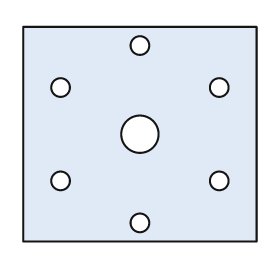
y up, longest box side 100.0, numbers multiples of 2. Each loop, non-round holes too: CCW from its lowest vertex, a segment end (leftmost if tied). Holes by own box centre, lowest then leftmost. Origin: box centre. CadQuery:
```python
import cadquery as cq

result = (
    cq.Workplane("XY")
    .moveTo(-50.0, -46.0)
    .lineTo(50.0, -46.0)
    .lineTo(50.0, 46.0)
    .lineTo(-50.0, 46.0)
    .close()
    .moveTo(0.0, -38.0)
    .circle(4.0)
    .moveTo(-34.0, -20.0)
    .circle(4.0)
    .moveTo(34.0, -20.0)
    .circle(4.0)
    .moveTo(0.0, 0.0)
    .circle(8.0)
    .moveTo(-34.0, 20.0)
    .circle(4.0)
    .moveTo(34.0, 20.0)
    .circle(4.0)
    .moveTo(0.0, 38.0)
    .circle(4.0)
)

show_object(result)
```